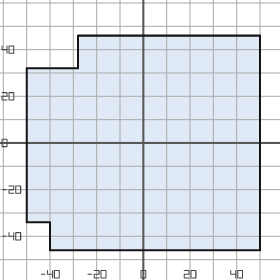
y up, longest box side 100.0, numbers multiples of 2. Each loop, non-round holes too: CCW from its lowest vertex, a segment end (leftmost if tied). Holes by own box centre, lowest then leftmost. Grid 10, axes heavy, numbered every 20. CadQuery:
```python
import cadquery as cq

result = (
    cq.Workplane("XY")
    .moveTo(-40.0, -46.0)
    .lineTo(50.0, -46.0)
    .lineTo(50.0, 46.0)
    .lineTo(-28.0, 46.0)
    .lineTo(-28.0, 32.0)
    .lineTo(-50.0, 32.0)
    .lineTo(-50.0, -34.0)
    .lineTo(-40.0, -34.0)
    .close()
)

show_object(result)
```